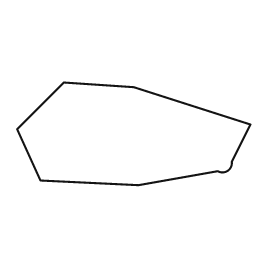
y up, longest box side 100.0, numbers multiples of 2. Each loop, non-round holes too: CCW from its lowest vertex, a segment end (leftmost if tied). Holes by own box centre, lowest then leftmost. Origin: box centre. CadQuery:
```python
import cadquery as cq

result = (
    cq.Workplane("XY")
    .moveTo(2.0, -22.0)
    .lineTo(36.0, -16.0)
    .threePointArc((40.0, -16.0), (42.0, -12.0))
    .lineTo(50.0, 4.0)
    .lineTo(0.0, 20.0)
    .lineTo(-30.0, 22.0)
    .lineTo(-50.0, 2.0)
    .lineTo(-40.0, -20.0)
    .close()
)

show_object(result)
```